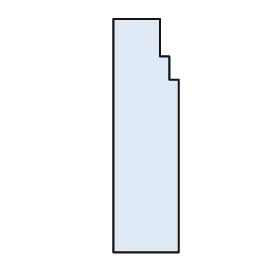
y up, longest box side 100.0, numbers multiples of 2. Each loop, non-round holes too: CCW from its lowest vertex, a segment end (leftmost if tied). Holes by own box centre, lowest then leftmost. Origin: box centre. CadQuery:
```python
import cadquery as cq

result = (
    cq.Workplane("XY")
    .moveTo(-14.0, -50.0)
    .lineTo(14.0, -50.0)
    .lineTo(14.0, 24.0)
    .lineTo(10.0, 24.0)
    .lineTo(10.0, 34.0)
    .lineTo(6.0, 34.0)
    .lineTo(6.0, 50.0)
    .lineTo(-14.0, 50.0)
    .close()
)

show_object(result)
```